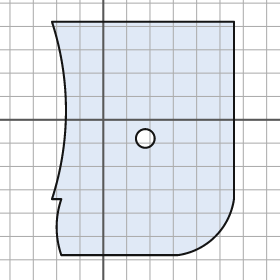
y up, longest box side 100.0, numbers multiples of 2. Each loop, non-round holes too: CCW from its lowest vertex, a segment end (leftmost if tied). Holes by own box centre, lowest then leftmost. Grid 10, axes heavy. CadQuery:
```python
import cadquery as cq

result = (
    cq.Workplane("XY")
    .moveTo(-18.0, -58.0)
    .lineTo(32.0, -58.0)
    .threePointArc((48.0, -50.0), (56.0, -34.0))
    .lineTo(56.0, 42.0)
    .lineTo(-22.0, 42.0)
    .threePointArc((-16.0, 4.0), (-22.0, -34.0))
    .lineTo(-18.0, -34.0)
    .threePointArc((-20.0, -46.0), (-18.0, -58.0))
    .close()
    .moveTo(18.0, -8.0)
    .circle(4.0)
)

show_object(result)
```